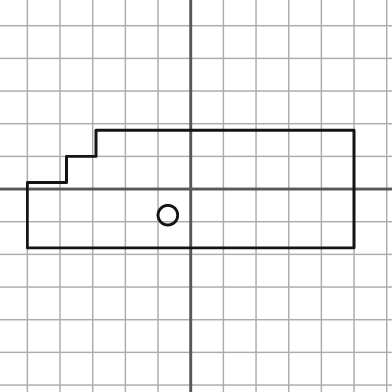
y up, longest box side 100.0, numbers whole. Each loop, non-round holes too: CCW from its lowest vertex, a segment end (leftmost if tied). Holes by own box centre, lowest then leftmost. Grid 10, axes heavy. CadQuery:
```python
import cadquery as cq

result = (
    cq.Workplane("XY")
    .moveTo(-50.0, -18.0)
    .lineTo(50.0, -18.0)
    .lineTo(50.0, 18.0)
    .lineTo(-29.0, 18.0)
    .lineTo(-29.0, 10.0)
    .lineTo(-38.0, 10.0)
    .lineTo(-38.0, 2.0)
    .lineTo(-50.0, 2.0)
    .close()
    .moveTo(-7.0, -8.0)
    .circle(3.0)
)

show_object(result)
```